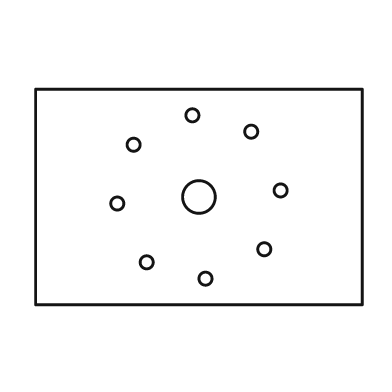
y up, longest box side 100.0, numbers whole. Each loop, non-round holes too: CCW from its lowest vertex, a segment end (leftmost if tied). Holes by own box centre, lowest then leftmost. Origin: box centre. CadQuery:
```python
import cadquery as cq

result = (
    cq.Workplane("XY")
    .moveTo(-50.0, -33.0)
    .lineTo(50.0, -33.0)
    .lineTo(50.0, 33.0)
    .lineTo(-50.0, 33.0)
    .close()
    .moveTo(2.0, -25.0)
    .circle(2.0)
    .moveTo(-16.0, -20.0)
    .circle(2.0)
    .moveTo(20.0, -16.0)
    .circle(2.0)
    .moveTo(-25.0, -2.0)
    .circle(2.0)
    .moveTo(0.0, 0.0)
    .circle(5.0)
    .moveTo(25.0, 2.0)
    .circle(2.0)
    .moveTo(-20.0, 16.0)
    .circle(2.0)
    .moveTo(16.0, 20.0)
    .circle(2.0)
    .moveTo(-2.0, 25.0)
    .circle(2.0)
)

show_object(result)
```